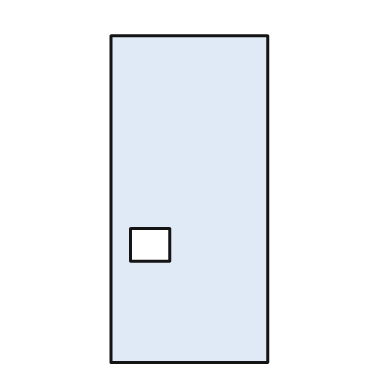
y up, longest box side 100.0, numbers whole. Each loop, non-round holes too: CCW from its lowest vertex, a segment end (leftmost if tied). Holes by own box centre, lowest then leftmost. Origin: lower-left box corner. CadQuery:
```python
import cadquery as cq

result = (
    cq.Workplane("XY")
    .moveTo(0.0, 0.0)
    .lineTo(48.0, 0.0)
    .lineTo(48.0, 100.0)
    .lineTo(0.0, 100.0)
    .close()
    .moveTo(6.0, 31.0)
    .lineTo(18.0, 31.0)
    .lineTo(18.0, 41.0)
    .lineTo(6.0, 41.0)
    .close()
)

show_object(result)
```